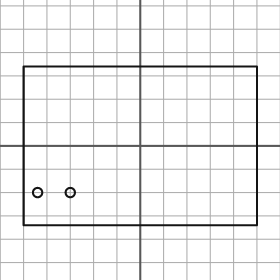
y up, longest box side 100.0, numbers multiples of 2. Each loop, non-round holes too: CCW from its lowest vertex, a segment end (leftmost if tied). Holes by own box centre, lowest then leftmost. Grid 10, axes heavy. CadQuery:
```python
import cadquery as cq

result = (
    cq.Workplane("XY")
    .moveTo(-50.0, -34.0)
    .lineTo(50.0, -34.0)
    .lineTo(50.0, 34.0)
    .lineTo(-50.0, 34.0)
    .close()
    .moveTo(-44.0, -20.0)
    .circle(2.0)
    .moveTo(-30.0, -20.0)
    .circle(2.0)
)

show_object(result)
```